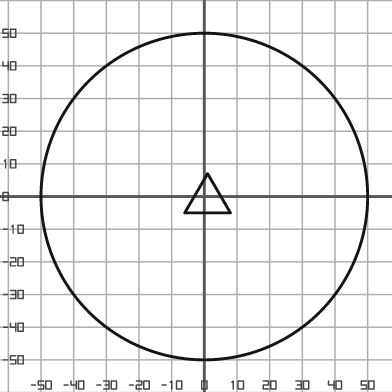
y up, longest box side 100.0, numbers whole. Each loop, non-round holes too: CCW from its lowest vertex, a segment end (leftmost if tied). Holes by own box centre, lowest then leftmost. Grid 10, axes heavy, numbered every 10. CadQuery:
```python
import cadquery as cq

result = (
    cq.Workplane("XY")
    .moveTo(0.0, 0.0)
    .circle(50.0)
    .moveTo(-6.0, -5.0)
    .lineTo(8.0, -5.0)
    .lineTo(1.0, 7.0)
    .close()
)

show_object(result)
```